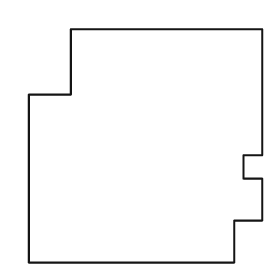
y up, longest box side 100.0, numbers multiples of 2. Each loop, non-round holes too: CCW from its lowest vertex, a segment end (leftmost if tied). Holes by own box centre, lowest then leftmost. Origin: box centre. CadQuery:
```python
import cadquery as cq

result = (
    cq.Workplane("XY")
    .moveTo(-50.0, -50.0)
    .lineTo(38.0, -50.0)
    .lineTo(38.0, -32.0)
    .lineTo(50.0, -32.0)
    .lineTo(50.0, -14.0)
    .lineTo(42.0, -14.0)
    .lineTo(42.0, -4.0)
    .lineTo(50.0, -4.0)
    .lineTo(50.0, 50.0)
    .lineTo(-32.0, 50.0)
    .lineTo(-32.0, 22.0)
    .lineTo(-50.0, 22.0)
    .close()
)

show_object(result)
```